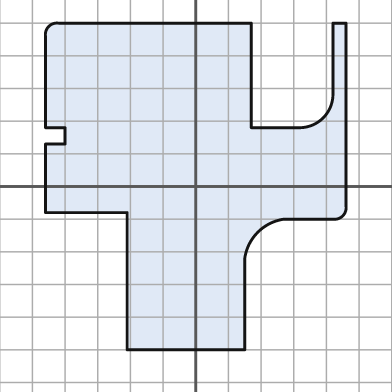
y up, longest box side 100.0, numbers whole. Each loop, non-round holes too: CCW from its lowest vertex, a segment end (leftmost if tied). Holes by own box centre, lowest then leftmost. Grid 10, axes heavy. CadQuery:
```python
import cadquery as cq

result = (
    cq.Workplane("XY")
    .moveTo(-21.0, -50.0)
    .lineTo(15.0, -50.0)
    .lineTo(15.0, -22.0)
    .threePointArc((19.0, -14.0), (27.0, -10.0))
    .lineTo(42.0, -10.0)
    .threePointArc((45.0, -9.0), (46.0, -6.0))
    .lineTo(46.0, 50.0)
    .lineTo(42.0, 50.0)
    .lineTo(42.0, 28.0)
    .threePointArc((39.0, 21.0), (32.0, 18.0))
    .lineTo(17.0, 18.0)
    .lineTo(17.0, 50.0)
    .lineTo(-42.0, 50.0)
    .threePointArc((-45.0, 49.0), (-46.0, 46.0))
    .lineTo(-46.0, 18.0)
    .lineTo(-40.0, 18.0)
    .lineTo(-40.0, 13.0)
    .lineTo(-46.0, 13.0)
    .lineTo(-46.0, -8.0)
    .lineTo(-21.0, -8.0)
    .close()
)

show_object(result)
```